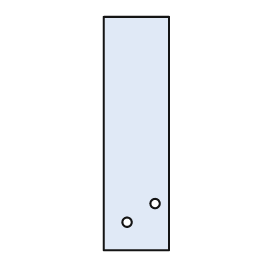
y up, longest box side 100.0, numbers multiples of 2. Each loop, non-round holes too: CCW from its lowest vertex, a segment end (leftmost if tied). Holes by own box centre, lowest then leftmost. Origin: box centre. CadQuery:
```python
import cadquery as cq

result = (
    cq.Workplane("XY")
    .moveTo(-14.0, -50.0)
    .lineTo(14.0, -50.0)
    .lineTo(14.0, 50.0)
    .lineTo(-14.0, 50.0)
    .close()
    .moveTo(-4.0, -38.0)
    .circle(2.0)
    .moveTo(8.0, -30.0)
    .circle(2.0)
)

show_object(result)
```